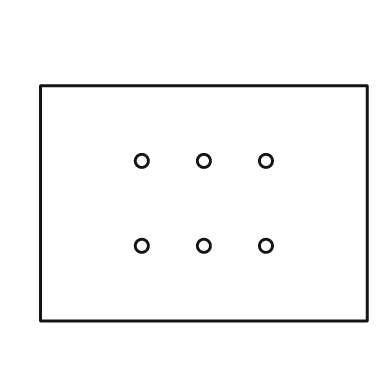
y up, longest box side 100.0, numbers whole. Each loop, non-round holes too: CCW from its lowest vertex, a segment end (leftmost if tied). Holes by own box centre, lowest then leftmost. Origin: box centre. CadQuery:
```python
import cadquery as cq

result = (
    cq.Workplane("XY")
    .moveTo(-50.0, -36.0)
    .lineTo(50.0, -36.0)
    .lineTo(50.0, 36.0)
    .lineTo(-50.0, 36.0)
    .close()
    .moveTo(-19.0, -13.0)
    .circle(2.0)
    .moveTo(0.0, -13.0)
    .circle(2.0)
    .moveTo(19.0, -13.0)
    .circle(2.0)
    .moveTo(-19.0, 13.0)
    .circle(2.0)
    .moveTo(0.0, 13.0)
    .circle(2.0)
    .moveTo(19.0, 13.0)
    .circle(2.0)
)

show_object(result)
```